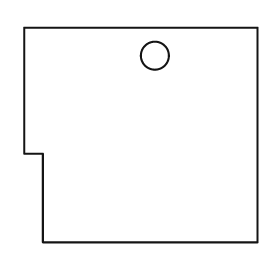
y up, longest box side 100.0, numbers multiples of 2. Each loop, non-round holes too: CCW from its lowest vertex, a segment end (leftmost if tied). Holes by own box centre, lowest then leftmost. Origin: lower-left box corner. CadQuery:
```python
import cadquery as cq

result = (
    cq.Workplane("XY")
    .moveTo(8.0, 0.0)
    .lineTo(100.0, 0.0)
    .lineTo(100.0, 92.0)
    .lineTo(0.0, 92.0)
    .lineTo(0.0, 38.0)
    .lineTo(8.0, 38.0)
    .close()
    .moveTo(56.0, 80.0)
    .circle(6.0)
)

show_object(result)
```